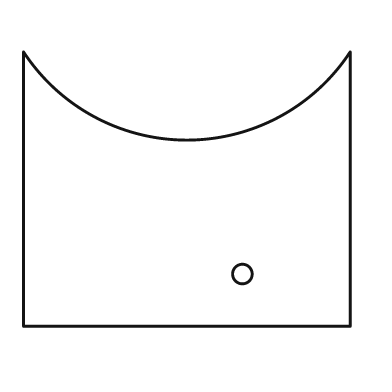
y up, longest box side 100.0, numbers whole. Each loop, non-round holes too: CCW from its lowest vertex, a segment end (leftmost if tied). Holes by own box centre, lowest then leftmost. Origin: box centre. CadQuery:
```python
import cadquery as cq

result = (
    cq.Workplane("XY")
    .moveTo(-50.0, -42.0)
    .lineTo(50.0, -42.0)
    .lineTo(50.0, 42.0)
    .threePointArc((0.0, 15.0), (-50.0, 42.0))
    .close()
    .moveTo(17.0, -26.0)
    .circle(3.0)
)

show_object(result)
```